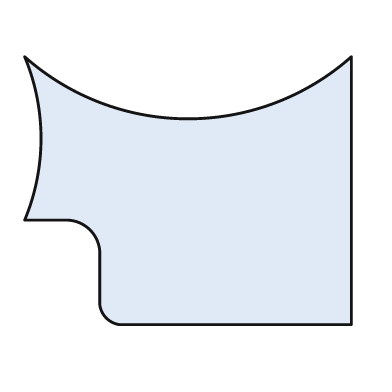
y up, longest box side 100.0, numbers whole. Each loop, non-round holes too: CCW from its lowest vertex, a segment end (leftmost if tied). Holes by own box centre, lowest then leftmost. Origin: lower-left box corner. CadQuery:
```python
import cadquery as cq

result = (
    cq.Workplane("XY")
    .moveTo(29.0, 0.0)
    .lineTo(100.0, 0.0)
    .lineTo(100.0, 82.0)
    .threePointArc((50.0, 63.0), (0.0, 82.0))
    .threePointArc((5.0, 57.0), (0.0, 32.0))
    .lineTo(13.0, 32.0)
    .threePointArc((20.0, 29.0), (23.0, 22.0))
    .lineTo(23.0, 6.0)
    .threePointArc((25.0, 2.0), (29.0, 0.0))
    .close()
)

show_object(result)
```